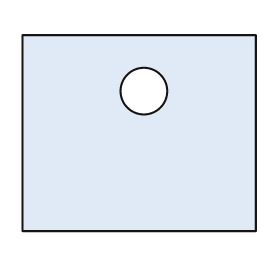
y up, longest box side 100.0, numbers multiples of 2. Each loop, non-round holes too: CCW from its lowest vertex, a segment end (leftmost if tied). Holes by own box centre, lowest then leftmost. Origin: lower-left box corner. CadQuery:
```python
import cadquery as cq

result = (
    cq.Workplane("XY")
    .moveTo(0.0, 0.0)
    .lineTo(100.0, 0.0)
    .lineTo(100.0, 84.0)
    .lineTo(0.0, 84.0)
    .close()
    .moveTo(52.0, 60.0)
    .circle(10.0)
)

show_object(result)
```